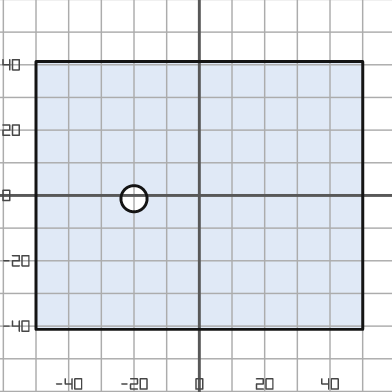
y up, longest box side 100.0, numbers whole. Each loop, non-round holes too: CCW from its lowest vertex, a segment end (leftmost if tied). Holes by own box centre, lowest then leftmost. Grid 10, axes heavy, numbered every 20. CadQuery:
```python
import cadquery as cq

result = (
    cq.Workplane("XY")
    .moveTo(-50.0, -41.0)
    .lineTo(50.0, -41.0)
    .lineTo(50.0, 41.0)
    .lineTo(-50.0, 41.0)
    .close()
    .moveTo(-20.0, -1.0)
    .circle(4.0)
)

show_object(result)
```